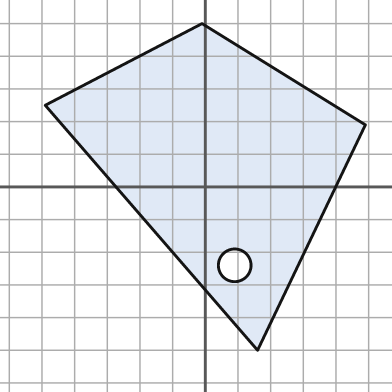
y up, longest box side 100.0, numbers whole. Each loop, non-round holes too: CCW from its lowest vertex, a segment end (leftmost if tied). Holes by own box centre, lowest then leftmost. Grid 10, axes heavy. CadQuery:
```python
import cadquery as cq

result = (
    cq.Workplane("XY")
    .moveTo(16.0, -50.0)
    .lineTo(49.0, 19.0)
    .lineTo(-1.0, 50.0)
    .lineTo(-49.0, 25.0)
    .close()
    .moveTo(9.0, -24.0)
    .circle(5.0)
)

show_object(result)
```